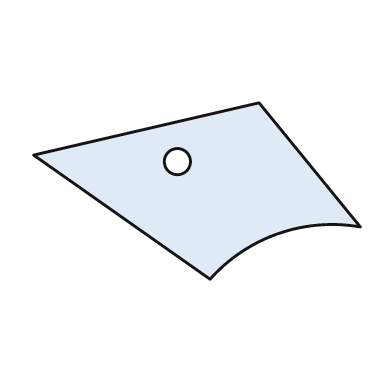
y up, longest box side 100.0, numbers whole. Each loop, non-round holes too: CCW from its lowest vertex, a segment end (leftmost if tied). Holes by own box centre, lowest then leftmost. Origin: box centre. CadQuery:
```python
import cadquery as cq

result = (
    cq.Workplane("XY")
    .moveTo(4.0, -27.0)
    .threePointArc((25.0, -13.0), (50.0, -11.0))
    .lineTo(19.0, 27.0)
    .lineTo(-50.0, 11.0)
    .close()
    .moveTo(-6.0, 9.0)
    .circle(4.0)
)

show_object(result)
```